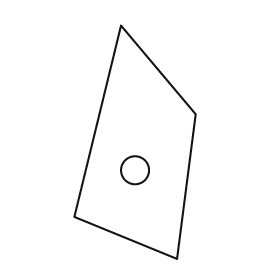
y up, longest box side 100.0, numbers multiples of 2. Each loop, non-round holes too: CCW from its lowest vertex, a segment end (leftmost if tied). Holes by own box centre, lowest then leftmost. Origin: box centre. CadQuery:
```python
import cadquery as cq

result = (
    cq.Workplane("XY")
    .moveTo(18.0, -50.0)
    .lineTo(26.0, 12.0)
    .lineTo(-6.0, 50.0)
    .lineTo(-26.0, -32.0)
    .close()
    .moveTo(0.0, -12.0)
    .circle(6.0)
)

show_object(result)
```